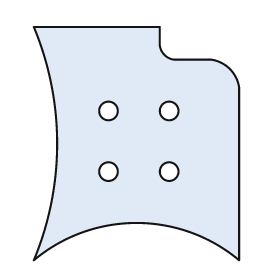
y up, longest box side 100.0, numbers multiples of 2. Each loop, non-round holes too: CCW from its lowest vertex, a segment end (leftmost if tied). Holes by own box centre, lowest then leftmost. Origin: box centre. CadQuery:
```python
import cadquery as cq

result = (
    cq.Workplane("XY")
    .moveTo(-44.0, -50.0)
    .threePointArc((0.0, -34.0), (44.0, -50.0))
    .lineTo(44.0, 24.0)
    .threePointArc((40.0, 32.0), (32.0, 36.0))
    .lineTo(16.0, 36.0)
    .threePointArc((12.0, 38.0), (10.0, 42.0))
    .lineTo(10.0, 50.0)
    .lineTo(-44.0, 50.0)
    .threePointArc((-34.0, 0.0), (-44.0, -50.0))
    .close()
    .moveTo(-12.0, -12.0)
    .circle(4.0)
    .moveTo(14.0, -12.0)
    .circle(4.0)
    .moveTo(-12.0, 14.0)
    .circle(4.0)
    .moveTo(14.0, 14.0)
    .circle(4.0)
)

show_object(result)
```